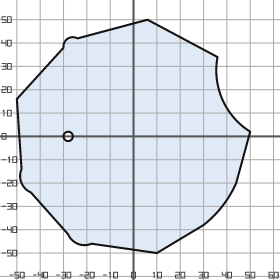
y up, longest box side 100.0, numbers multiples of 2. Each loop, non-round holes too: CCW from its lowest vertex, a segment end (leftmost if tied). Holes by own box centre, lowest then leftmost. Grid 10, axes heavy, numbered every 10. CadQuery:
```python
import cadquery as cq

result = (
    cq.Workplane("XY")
    .moveTo(10.0, -50.0)
    .lineTo(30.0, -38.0)
    .threePointArc((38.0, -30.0), (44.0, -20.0))
    .lineTo(50.0, 2.0)
    .threePointArc((38.0, 16.0), (36.0, 34.0))
    .lineTo(6.0, 50.0)
    .lineTo(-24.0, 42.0)
    .threePointArc((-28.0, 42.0), (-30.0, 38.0))
    .lineTo(-50.0, 16.0)
    .lineTo(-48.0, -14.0)
    .threePointArc((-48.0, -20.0), (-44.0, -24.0))
    .lineTo(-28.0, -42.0)
    .threePointArc((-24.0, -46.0), (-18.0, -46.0))
    .close()
    .moveTo(-28.0, 0.0)
    .circle(2.0)
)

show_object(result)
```